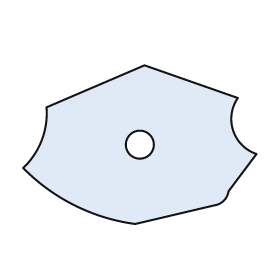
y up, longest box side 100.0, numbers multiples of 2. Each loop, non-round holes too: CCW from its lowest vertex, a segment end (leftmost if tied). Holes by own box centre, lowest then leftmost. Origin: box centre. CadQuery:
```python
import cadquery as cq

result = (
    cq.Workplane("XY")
    .moveTo(-2.0, -34.0)
    .lineTo(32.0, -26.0)
    .threePointArc((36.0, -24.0), (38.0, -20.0))
    .lineTo(50.0, -4.0)
    .threePointArc((40.0, 6.0), (42.0, 20.0))
    .lineTo(2.0, 34.0)
    .lineTo(-40.0, 16.0)
    .threePointArc((-42.0, 2.0), (-50.0, -10.0))
    .threePointArc((-28.0, -26.0), (-2.0, -34.0))
    .close()
    .moveTo(0.0, 0.0)
    .circle(6.0)
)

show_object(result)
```